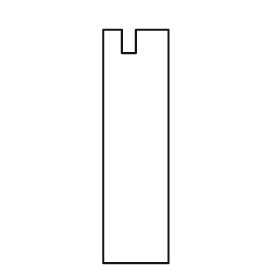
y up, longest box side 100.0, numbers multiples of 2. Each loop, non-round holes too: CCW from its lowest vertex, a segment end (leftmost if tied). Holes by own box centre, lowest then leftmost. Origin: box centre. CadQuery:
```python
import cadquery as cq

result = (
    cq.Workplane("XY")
    .moveTo(-14.0, -50.0)
    .lineTo(14.0, -50.0)
    .lineTo(14.0, 50.0)
    .lineTo(0.0, 50.0)
    .lineTo(0.0, 40.0)
    .lineTo(-6.0, 40.0)
    .lineTo(-6.0, 50.0)
    .lineTo(-14.0, 50.0)
    .close()
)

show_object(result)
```